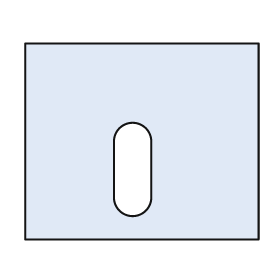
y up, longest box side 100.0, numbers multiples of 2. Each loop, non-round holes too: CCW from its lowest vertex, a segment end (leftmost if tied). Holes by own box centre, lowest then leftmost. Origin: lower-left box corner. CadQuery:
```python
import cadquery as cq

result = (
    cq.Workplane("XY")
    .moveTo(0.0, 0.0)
    .lineTo(100.0, 0.0)
    .lineTo(100.0, 84.0)
    .lineTo(0.0, 84.0)
    .close()
    .moveTo(38.0, 18.0)
    .threePointArc((46.0, 10.0), (54.0, 18.0))
    .lineTo(54.0, 42.0)
    .threePointArc((46.0, 50.0), (38.0, 42.0))
    .close()
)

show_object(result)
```